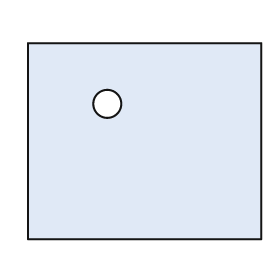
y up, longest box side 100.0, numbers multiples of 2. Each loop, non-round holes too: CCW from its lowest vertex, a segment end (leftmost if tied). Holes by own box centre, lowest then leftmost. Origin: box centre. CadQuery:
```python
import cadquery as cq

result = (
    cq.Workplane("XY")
    .moveTo(-50.0, -42.0)
    .lineTo(50.0, -42.0)
    .lineTo(50.0, 42.0)
    .lineTo(-50.0, 42.0)
    .close()
    .moveTo(-16.0, 16.0)
    .circle(6.0)
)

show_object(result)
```